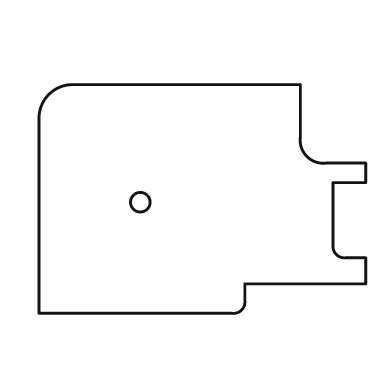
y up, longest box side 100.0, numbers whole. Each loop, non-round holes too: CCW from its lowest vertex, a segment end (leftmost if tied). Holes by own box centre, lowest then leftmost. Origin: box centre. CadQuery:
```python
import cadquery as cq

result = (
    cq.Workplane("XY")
    .moveTo(-50.0, -35.0)
    .lineTo(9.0, -35.0)
    .threePointArc((12.0, -34.0), (13.0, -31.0))
    .lineTo(13.0, -26.0)
    .lineTo(50.0, -26.0)
    .lineTo(50.0, -18.0)
    .lineTo(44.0, -18.0)
    .threePointArc((41.0, -17.0), (40.0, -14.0))
    .lineTo(40.0, 5.0)
    .lineTo(50.0, 5.0)
    .lineTo(50.0, 11.0)
    .lineTo(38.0, 11.0)
    .threePointArc((32.0, 13.0), (30.0, 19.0))
    .lineTo(30.0, 35.0)
    .lineTo(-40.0, 35.0)
    .threePointArc((-47.0, 32.0), (-50.0, 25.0))
    .close()
    .moveTo(-19.0, -1.0)
    .circle(3.0)
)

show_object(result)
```